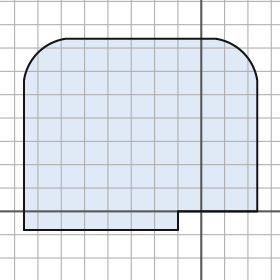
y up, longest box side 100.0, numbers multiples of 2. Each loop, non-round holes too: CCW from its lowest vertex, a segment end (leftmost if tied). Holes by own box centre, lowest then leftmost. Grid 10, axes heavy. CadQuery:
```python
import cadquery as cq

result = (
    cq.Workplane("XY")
    .moveTo(-76.0, -8.0)
    .lineTo(-10.0, -8.0)
    .lineTo(-10.0, 0.0)
    .lineTo(24.0, 0.0)
    .lineTo(24.0, 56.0)
    .threePointArc((18.0, 68.0), (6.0, 74.0))
    .lineTo(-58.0, 74.0)
    .threePointArc((-70.0, 68.0), (-76.0, 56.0))
    .close()
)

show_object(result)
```